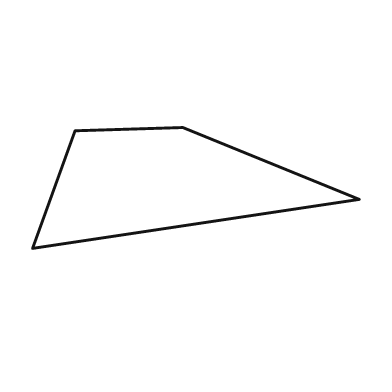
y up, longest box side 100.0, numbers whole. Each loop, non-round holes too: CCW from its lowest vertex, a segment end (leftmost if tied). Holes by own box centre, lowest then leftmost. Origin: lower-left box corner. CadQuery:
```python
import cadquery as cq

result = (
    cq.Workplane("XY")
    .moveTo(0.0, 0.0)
    .lineTo(100.0, 15.0)
    .lineTo(46.0, 37.0)
    .lineTo(13.0, 36.0)
    .close()
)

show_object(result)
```